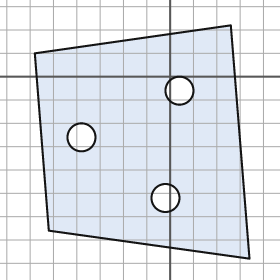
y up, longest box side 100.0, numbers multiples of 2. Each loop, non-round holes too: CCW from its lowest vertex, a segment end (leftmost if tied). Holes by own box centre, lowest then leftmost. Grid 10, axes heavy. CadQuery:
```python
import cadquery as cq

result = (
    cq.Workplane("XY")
    .moveTo(34.0, -78.0)
    .lineTo(26.0, 22.0)
    .lineTo(-58.0, 10.0)
    .lineTo(-52.0, -66.0)
    .close()
    .moveTo(-2.0, -52.0)
    .circle(6.0)
    .moveTo(-38.0, -26.0)
    .circle(6.0)
    .moveTo(4.0, -6.0)
    .circle(6.0)
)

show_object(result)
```